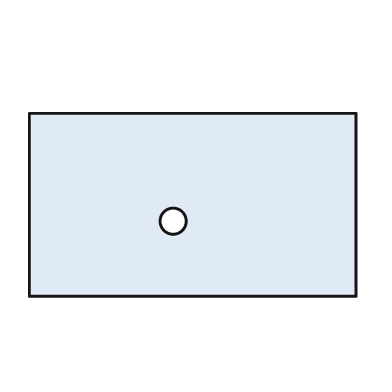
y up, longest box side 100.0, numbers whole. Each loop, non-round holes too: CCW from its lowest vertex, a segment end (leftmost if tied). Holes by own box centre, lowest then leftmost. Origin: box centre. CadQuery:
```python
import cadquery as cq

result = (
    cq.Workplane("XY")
    .moveTo(-50.0, -28.0)
    .lineTo(50.0, -28.0)
    .lineTo(50.0, 28.0)
    .lineTo(-50.0, 28.0)
    .close()
    .moveTo(-6.0, -5.0)
    .circle(4.0)
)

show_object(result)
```